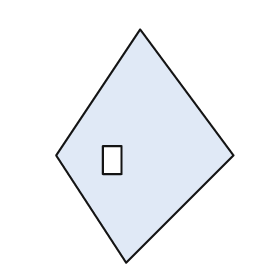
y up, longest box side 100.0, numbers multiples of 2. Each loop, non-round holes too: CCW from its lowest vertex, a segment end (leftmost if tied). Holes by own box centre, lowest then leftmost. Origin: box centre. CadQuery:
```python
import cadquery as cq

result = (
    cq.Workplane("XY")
    .moveTo(-8.0, -50.0)
    .lineTo(38.0, -4.0)
    .lineTo(-2.0, 50.0)
    .lineTo(-38.0, -4.0)
    .close()
    .moveTo(-18.0, -12.0)
    .lineTo(-10.0, -12.0)
    .lineTo(-10.0, 0.0)
    .lineTo(-18.0, 0.0)
    .close()
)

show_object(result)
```